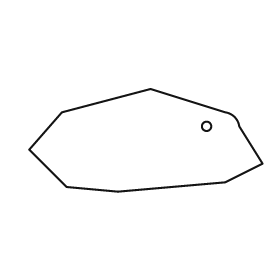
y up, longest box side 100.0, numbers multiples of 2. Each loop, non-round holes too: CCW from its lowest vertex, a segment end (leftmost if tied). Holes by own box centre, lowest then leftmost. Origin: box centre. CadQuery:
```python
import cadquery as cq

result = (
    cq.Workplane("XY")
    .moveTo(-12.0, -22.0)
    .lineTo(34.0, -18.0)
    .lineTo(50.0, -10.0)
    .lineTo(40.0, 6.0)
    .threePointArc((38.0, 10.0), (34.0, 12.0))
    .lineTo(2.0, 22.0)
    .lineTo(-36.0, 12.0)
    .lineTo(-50.0, -4.0)
    .lineTo(-34.0, -20.0)
    .close()
    .moveTo(26.0, 6.0)
    .circle(2.0)
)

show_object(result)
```